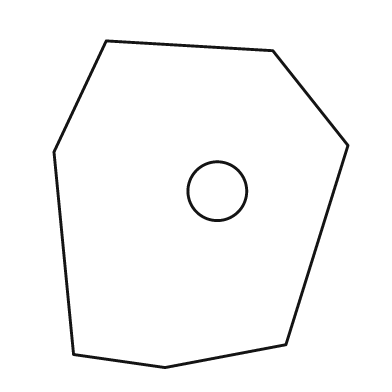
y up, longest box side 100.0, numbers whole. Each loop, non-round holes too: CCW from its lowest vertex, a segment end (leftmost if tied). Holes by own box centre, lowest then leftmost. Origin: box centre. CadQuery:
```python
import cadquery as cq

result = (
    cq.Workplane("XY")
    .moveTo(-11.0, -50.0)
    .lineTo(26.0, -43.0)
    .lineTo(45.0, 18.0)
    .lineTo(22.0, 47.0)
    .lineTo(-29.0, 50.0)
    .lineTo(-45.0, 16.0)
    .lineTo(-39.0, -46.0)
    .close()
    .moveTo(5.0, 4.0)
    .circle(9.0)
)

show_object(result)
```